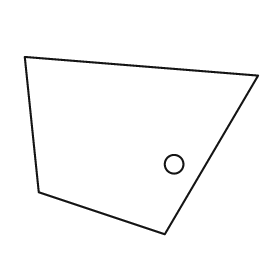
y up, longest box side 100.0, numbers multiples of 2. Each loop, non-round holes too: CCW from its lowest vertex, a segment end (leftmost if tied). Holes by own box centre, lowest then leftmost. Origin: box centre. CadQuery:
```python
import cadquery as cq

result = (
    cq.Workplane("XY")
    .moveTo(10.0, -38.0)
    .lineTo(50.0, 30.0)
    .lineTo(-50.0, 38.0)
    .lineTo(-44.0, -20.0)
    .close()
    .moveTo(14.0, -8.0)
    .circle(4.0)
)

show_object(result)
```